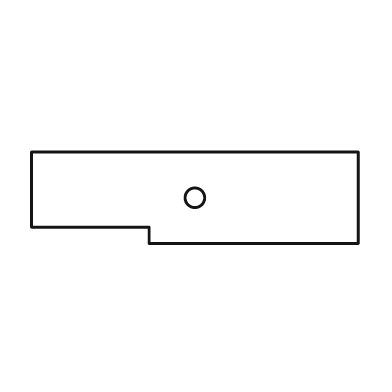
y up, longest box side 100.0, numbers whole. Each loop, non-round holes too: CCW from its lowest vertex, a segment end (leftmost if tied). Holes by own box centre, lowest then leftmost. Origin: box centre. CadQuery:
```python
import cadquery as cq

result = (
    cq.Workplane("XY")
    .moveTo(-14.0, -14.0)
    .lineTo(50.0, -14.0)
    .lineTo(50.0, 14.0)
    .lineTo(-50.0, 14.0)
    .lineTo(-50.0, -9.0)
    .lineTo(-14.0, -9.0)
    .close()
    .moveTo(0.0, 0.0)
    .circle(3.0)
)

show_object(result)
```